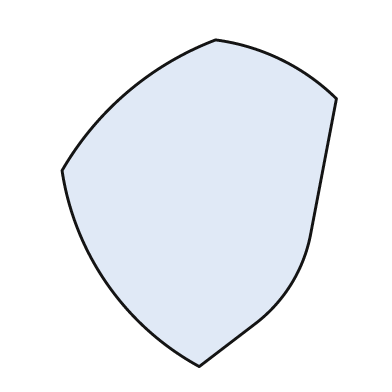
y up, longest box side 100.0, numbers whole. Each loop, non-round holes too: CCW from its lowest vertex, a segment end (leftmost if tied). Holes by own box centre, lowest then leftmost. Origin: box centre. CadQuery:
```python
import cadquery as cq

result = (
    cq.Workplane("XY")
    .moveTo(0.0, -50.0)
    .lineTo(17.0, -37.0)
    .threePointArc((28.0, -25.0), (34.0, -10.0))
    .lineTo(42.0, 32.0)
    .threePointArc((25.0, 44.0), (5.0, 50.0))
    .threePointArc((-22.0, 34.0), (-42.0, 10.0))
    .threePointArc((-28.0, -25.0), (0.0, -50.0))
    .close()
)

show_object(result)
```